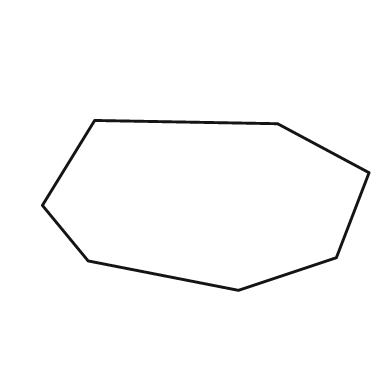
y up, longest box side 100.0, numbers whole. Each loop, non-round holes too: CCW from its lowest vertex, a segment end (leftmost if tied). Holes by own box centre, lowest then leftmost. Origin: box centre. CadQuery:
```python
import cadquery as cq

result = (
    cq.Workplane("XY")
    .moveTo(10.0, -26.0)
    .lineTo(40.0, -16.0)
    .lineTo(50.0, 10.0)
    .lineTo(22.0, 25.0)
    .lineTo(-34.0, 26.0)
    .lineTo(-50.0, 0.0)
    .lineTo(-36.0, -17.0)
    .close()
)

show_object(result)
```